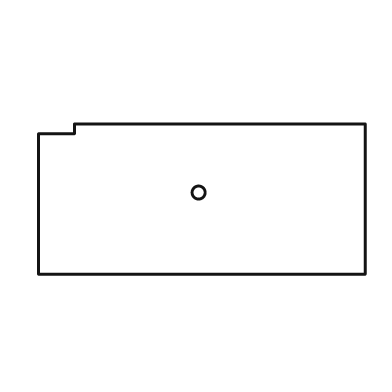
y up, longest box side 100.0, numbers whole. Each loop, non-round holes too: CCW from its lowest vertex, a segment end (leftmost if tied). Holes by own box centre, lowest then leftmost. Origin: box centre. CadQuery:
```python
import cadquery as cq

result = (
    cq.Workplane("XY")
    .moveTo(-50.0, -23.0)
    .lineTo(50.0, -23.0)
    .lineTo(50.0, 23.0)
    .lineTo(-39.0, 23.0)
    .lineTo(-39.0, 20.0)
    .lineTo(-50.0, 20.0)
    .close()
    .moveTo(-1.0, 2.0)
    .circle(2.0)
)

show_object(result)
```